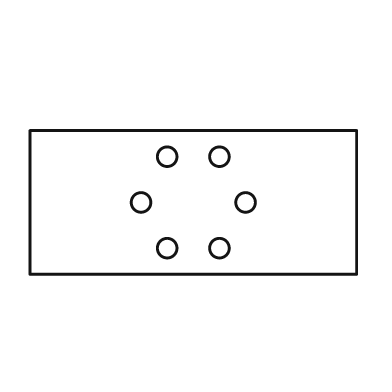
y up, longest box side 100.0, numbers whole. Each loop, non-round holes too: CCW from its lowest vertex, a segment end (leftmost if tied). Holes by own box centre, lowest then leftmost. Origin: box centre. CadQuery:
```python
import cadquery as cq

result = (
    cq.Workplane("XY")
    .moveTo(-50.0, -22.0)
    .lineTo(50.0, -22.0)
    .lineTo(50.0, 22.0)
    .lineTo(-50.0, 22.0)
    .close()
    .moveTo(-8.0, -14.0)
    .circle(3.0)
    .moveTo(8.0, -14.0)
    .circle(3.0)
    .moveTo(-16.0, 0.0)
    .circle(3.0)
    .moveTo(16.0, 0.0)
    .circle(3.0)
    .moveTo(-8.0, 14.0)
    .circle(3.0)
    .moveTo(8.0, 14.0)
    .circle(3.0)
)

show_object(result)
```